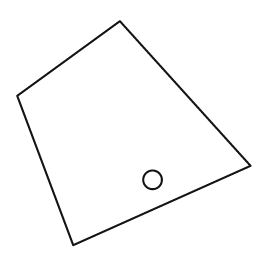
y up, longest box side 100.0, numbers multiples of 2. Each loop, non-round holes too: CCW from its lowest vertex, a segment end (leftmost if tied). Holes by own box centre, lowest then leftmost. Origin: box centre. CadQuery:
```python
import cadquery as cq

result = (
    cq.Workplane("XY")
    .moveTo(-26.0, -48.0)
    .lineTo(50.0, -14.0)
    .lineTo(-6.0, 48.0)
    .lineTo(-50.0, 16.0)
    .close()
    .moveTo(8.0, -20.0)
    .circle(4.0)
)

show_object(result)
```